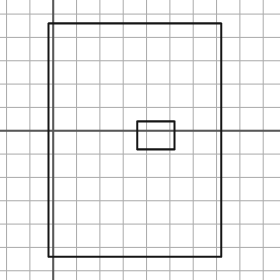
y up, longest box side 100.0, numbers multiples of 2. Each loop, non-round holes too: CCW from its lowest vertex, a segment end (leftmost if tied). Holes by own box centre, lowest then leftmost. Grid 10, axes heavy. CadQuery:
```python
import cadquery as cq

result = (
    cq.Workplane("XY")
    .moveTo(-2.0, -54.0)
    .lineTo(72.0, -54.0)
    .lineTo(72.0, 46.0)
    .lineTo(-2.0, 46.0)
    .close()
    .moveTo(36.0, -8.0)
    .lineTo(52.0, -8.0)
    .lineTo(52.0, 4.0)
    .lineTo(36.0, 4.0)
    .close()
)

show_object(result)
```